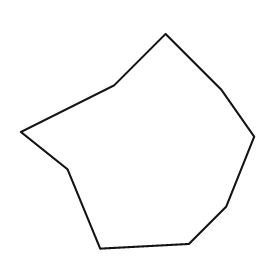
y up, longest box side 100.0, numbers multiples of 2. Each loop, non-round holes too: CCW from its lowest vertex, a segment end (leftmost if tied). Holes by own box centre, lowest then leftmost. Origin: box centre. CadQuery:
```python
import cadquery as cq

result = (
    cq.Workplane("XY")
    .moveTo(-16.0, -46.0)
    .lineTo(22.0, -44.0)
    .lineTo(38.0, -28.0)
    .lineTo(50.0, 2.0)
    .lineTo(36.0, 22.0)
    .lineTo(12.0, 46.0)
    .lineTo(-10.0, 24.0)
    .lineTo(-50.0, 4.0)
    .lineTo(-30.0, -12.0)
    .close()
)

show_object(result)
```